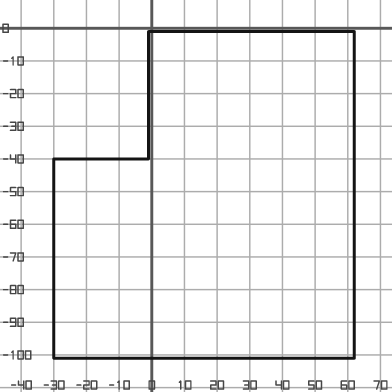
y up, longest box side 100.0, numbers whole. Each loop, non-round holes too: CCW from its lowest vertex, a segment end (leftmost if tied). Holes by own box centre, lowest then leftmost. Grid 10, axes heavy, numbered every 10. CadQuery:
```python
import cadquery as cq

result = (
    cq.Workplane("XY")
    .moveTo(-30.0, -101.0)
    .lineTo(62.0, -101.0)
    .lineTo(62.0, -1.0)
    .lineTo(-1.0, -1.0)
    .lineTo(-1.0, -40.0)
    .lineTo(-30.0, -40.0)
    .close()
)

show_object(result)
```